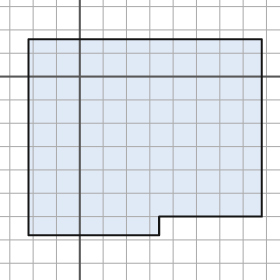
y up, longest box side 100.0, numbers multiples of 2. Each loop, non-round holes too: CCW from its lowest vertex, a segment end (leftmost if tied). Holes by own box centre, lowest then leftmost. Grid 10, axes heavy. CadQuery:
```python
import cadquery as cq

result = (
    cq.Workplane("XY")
    .moveTo(-22.0, -68.0)
    .lineTo(34.0, -68.0)
    .lineTo(34.0, -60.0)
    .lineTo(78.0, -60.0)
    .lineTo(78.0, 16.0)
    .lineTo(-22.0, 16.0)
    .close()
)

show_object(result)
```